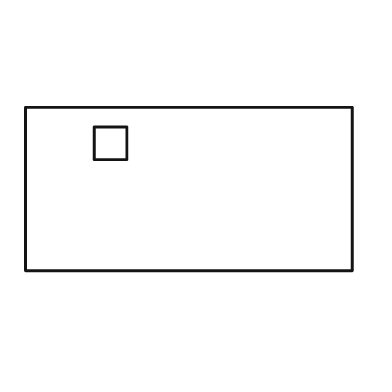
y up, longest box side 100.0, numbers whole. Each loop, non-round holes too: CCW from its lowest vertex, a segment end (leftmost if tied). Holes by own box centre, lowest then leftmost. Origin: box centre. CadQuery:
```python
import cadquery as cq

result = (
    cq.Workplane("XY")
    .moveTo(-50.0, -25.0)
    .lineTo(50.0, -25.0)
    .lineTo(50.0, 25.0)
    .lineTo(-50.0, 25.0)
    .close()
    .moveTo(-29.0, 9.0)
    .lineTo(-19.0, 9.0)
    .lineTo(-19.0, 19.0)
    .lineTo(-29.0, 19.0)
    .close()
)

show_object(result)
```